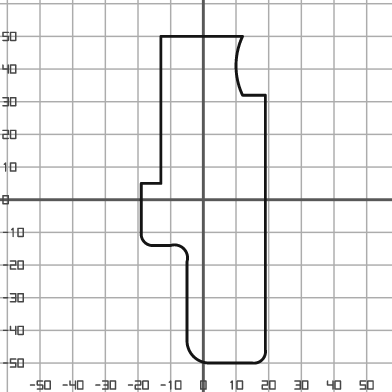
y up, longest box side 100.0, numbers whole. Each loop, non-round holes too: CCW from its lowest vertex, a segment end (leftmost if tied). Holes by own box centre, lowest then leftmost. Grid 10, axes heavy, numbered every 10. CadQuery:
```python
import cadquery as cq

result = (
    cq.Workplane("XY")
    .moveTo(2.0, -50.0)
    .lineTo(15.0, -50.0)
    .threePointArc((18.0, -49.0), (19.0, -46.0))
    .lineTo(19.0, 32.0)
    .lineTo(12.0, 32.0)
    .threePointArc((10.0, 41.0), (12.0, 50.0))
    .lineTo(-13.0, 50.0)
    .lineTo(-13.0, 5.0)
    .lineTo(-19.0, 5.0)
    .lineTo(-19.0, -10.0)
    .threePointArc((-18.0, -13.0), (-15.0, -14.0))
    .lineTo(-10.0, -14.0)
    .threePointArc((-6.0, -15.0), (-5.0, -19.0))
    .lineTo(-5.0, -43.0)
    .threePointArc((-3.0, -48.0), (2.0, -50.0))
    .close()
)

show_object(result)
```